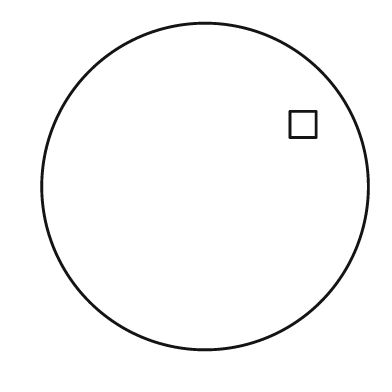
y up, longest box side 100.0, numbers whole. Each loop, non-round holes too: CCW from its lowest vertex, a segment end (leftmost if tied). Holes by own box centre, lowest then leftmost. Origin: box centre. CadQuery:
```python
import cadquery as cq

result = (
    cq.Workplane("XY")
    .moveTo(0.0, 0.0)
    .circle(50.0)
    .moveTo(26.0, 15.0)
    .lineTo(34.0, 15.0)
    .lineTo(34.0, 23.0)
    .lineTo(26.0, 23.0)
    .close()
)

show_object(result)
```